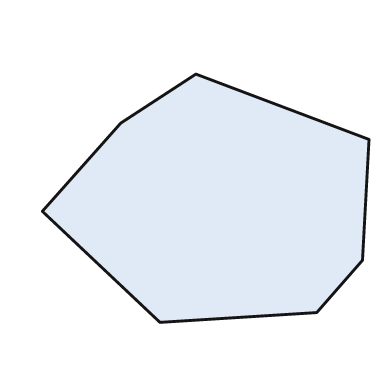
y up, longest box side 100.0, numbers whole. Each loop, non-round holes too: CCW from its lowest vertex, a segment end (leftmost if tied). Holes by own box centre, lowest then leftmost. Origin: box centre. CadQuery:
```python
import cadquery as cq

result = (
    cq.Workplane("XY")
    .moveTo(-14.0, -38.0)
    .lineTo(34.0, -35.0)
    .lineTo(48.0, -19.0)
    .lineTo(50.0, 18.0)
    .lineTo(-3.0, 38.0)
    .lineTo(-26.0, 23.0)
    .lineTo(-50.0, -4.0)
    .close()
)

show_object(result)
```